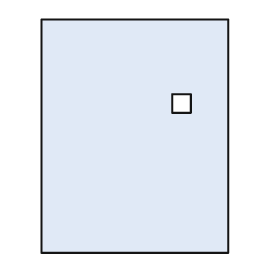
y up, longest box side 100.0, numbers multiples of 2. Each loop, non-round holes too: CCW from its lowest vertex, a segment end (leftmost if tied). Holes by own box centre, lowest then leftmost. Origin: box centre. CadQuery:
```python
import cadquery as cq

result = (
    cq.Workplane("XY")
    .moveTo(-40.0, -50.0)
    .lineTo(40.0, -50.0)
    .lineTo(40.0, 50.0)
    .lineTo(-40.0, 50.0)
    .close()
    .moveTo(16.0, 10.0)
    .lineTo(24.0, 10.0)
    .lineTo(24.0, 18.0)
    .lineTo(16.0, 18.0)
    .close()
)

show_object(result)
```